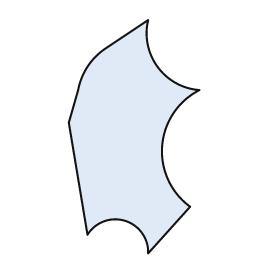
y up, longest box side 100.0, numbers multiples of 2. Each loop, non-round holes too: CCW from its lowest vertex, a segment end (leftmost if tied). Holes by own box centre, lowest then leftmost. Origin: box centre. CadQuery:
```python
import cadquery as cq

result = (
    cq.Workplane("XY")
    .moveTo(6.0, -50.0)
    .lineTo(24.0, -30.0)
    .threePointArc((12.0, -4.0), (28.0, 20.0))
    .threePointArc((10.0, 30.0), (6.0, 50.0))
    .lineTo(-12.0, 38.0)
    .threePointArc((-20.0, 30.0), (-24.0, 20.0))
    .lineTo(-28.0, 6.0)
    .lineTo(-20.0, -42.0)
    .threePointArc((-4.0, -36.0), (6.0, -50.0))
    .close()
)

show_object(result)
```